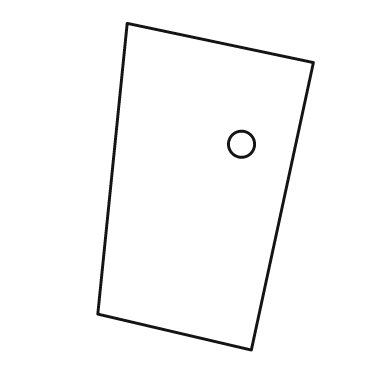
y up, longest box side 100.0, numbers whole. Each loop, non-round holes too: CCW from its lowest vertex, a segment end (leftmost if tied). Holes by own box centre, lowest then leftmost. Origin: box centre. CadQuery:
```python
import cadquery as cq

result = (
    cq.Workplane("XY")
    .moveTo(14.0, -50.0)
    .lineTo(33.0, 38.0)
    .lineTo(-24.0, 50.0)
    .lineTo(-33.0, -39.0)
    .close()
    .moveTo(11.0, 13.0)
    .circle(4.0)
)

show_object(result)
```